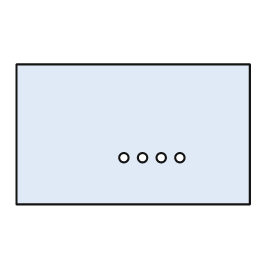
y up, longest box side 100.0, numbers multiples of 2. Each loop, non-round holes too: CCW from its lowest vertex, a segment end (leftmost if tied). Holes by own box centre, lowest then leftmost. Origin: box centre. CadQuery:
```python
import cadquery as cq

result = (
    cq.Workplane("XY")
    .moveTo(-50.0, -30.0)
    .lineTo(50.0, -30.0)
    .lineTo(50.0, 30.0)
    .lineTo(-50.0, 30.0)
    .close()
    .moveTo(-4.0, -10.0)
    .circle(2.0)
    .moveTo(4.0, -10.0)
    .circle(2.0)
    .moveTo(12.0, -10.0)
    .circle(2.0)
    .moveTo(20.0, -10.0)
    .circle(2.0)
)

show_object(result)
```